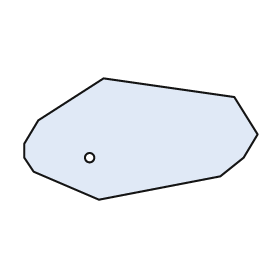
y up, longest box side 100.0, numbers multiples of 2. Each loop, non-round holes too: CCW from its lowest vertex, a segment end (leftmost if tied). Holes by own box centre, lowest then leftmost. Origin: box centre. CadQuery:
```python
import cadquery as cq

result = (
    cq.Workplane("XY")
    .moveTo(-18.0, -26.0)
    .lineTo(34.0, -16.0)
    .lineTo(44.0, -8.0)
    .lineTo(50.0, 2.0)
    .lineTo(40.0, 18.0)
    .lineTo(-16.0, 26.0)
    .lineTo(-44.0, 8.0)
    .lineTo(-50.0, -2.0)
    .lineTo(-50.0, -8.0)
    .lineTo(-46.0, -14.0)
    .close()
    .moveTo(-22.0, -8.0)
    .circle(2.0)
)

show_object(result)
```